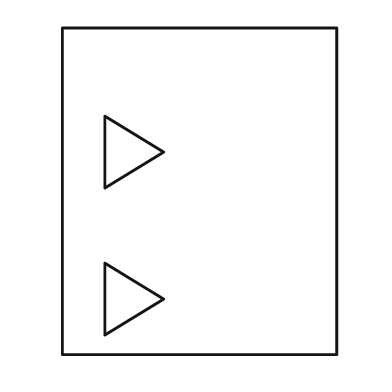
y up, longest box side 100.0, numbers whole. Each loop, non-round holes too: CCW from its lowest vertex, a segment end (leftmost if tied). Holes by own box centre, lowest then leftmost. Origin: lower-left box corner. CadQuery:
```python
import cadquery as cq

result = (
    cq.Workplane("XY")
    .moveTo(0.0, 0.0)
    .lineTo(84.0, 0.0)
    .lineTo(84.0, 100.0)
    .lineTo(0.0, 100.0)
    .close()
    .moveTo(13.0, 6.0)
    .lineTo(31.0, 17.0)
    .lineTo(13.0, 28.0)
    .close()
    .moveTo(13.0, 51.0)
    .lineTo(31.0, 62.0)
    .lineTo(13.0, 73.0)
    .close()
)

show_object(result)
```